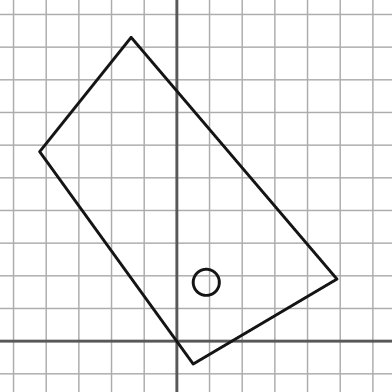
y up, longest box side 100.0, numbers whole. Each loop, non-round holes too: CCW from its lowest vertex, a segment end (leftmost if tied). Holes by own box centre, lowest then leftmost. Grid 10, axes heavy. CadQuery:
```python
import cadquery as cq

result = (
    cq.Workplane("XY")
    .moveTo(5.0, -7.0)
    .lineTo(49.0, 19.0)
    .lineTo(-14.0, 93.0)
    .lineTo(-42.0, 58.0)
    .close()
    .moveTo(9.0, 18.0)
    .circle(4.0)
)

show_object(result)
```